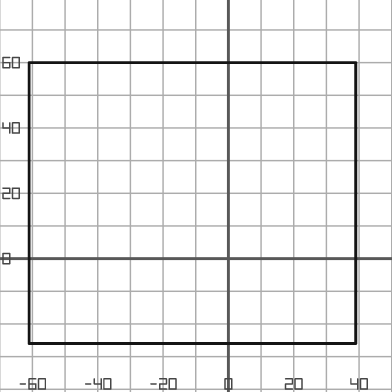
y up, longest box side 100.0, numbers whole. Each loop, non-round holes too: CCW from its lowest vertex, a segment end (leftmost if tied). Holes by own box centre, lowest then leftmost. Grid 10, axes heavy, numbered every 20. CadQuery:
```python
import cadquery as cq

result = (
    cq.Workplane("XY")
    .moveTo(-61.0, -26.0)
    .lineTo(39.0, -26.0)
    .lineTo(39.0, 60.0)
    .lineTo(-61.0, 60.0)
    .close()
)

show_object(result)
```